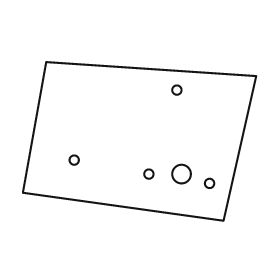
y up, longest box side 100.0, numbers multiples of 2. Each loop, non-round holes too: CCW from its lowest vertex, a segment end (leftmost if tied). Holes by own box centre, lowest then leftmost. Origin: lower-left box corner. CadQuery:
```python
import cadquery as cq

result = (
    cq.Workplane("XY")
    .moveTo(86.0, 0.0)
    .lineTo(100.0, 62.0)
    .lineTo(10.0, 68.0)
    .lineTo(0.0, 12.0)
    .close()
    .moveTo(80.0, 16.0)
    .circle(2.0)
    .moveTo(54.0, 20.0)
    .circle(2.0)
    .moveTo(68.0, 20.0)
    .circle(4.0)
    .moveTo(22.0, 26.0)
    .circle(2.0)
    .moveTo(66.0, 56.0)
    .circle(2.0)
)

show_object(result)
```